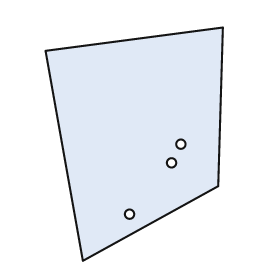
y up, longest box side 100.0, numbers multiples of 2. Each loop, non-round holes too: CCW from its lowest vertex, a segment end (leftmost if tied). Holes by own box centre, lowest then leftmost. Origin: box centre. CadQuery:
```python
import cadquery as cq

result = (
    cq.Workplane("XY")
    .moveTo(-22.0, -50.0)
    .lineTo(36.0, -18.0)
    .lineTo(38.0, 50.0)
    .lineTo(-38.0, 40.0)
    .close()
    .moveTo(-2.0, -30.0)
    .circle(2.0)
    .moveTo(16.0, -8.0)
    .circle(2.0)
    .moveTo(20.0, 0.0)
    .circle(2.0)
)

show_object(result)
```